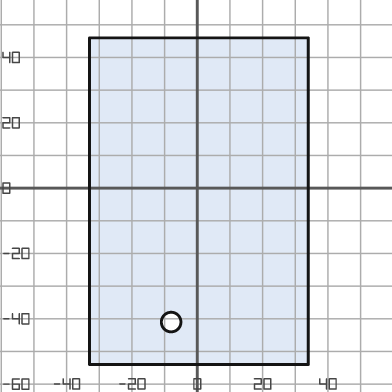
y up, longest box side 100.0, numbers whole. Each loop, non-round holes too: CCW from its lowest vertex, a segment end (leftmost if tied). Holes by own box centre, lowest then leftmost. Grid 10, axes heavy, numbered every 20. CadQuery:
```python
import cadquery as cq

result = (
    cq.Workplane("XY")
    .moveTo(-33.0, -54.0)
    .lineTo(34.0, -54.0)
    .lineTo(34.0, 46.0)
    .lineTo(-33.0, 46.0)
    .close()
    .moveTo(-8.0, -41.0)
    .circle(3.0)
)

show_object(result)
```